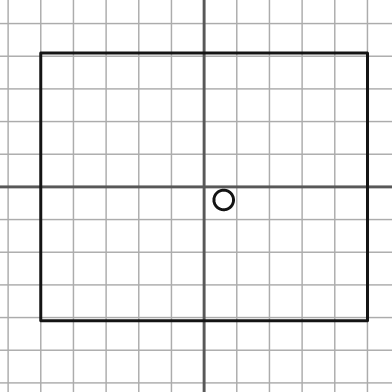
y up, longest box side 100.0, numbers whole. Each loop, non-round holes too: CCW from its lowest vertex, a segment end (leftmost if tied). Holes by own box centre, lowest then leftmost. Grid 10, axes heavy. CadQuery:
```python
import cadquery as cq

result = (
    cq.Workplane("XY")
    .moveTo(-50.0, -41.0)
    .lineTo(50.0, -41.0)
    .lineTo(50.0, 41.0)
    .lineTo(-50.0, 41.0)
    .close()
    .moveTo(6.0, -4.0)
    .circle(3.0)
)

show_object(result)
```